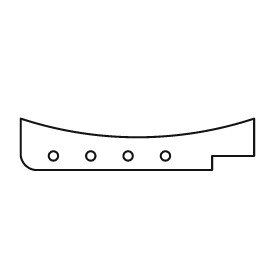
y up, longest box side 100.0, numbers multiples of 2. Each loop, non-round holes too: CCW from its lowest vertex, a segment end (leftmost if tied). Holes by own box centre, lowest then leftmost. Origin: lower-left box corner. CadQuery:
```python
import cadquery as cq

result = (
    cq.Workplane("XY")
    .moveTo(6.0, 0.0)
    .lineTo(82.0, 0.0)
    .lineTo(82.0, 6.0)
    .lineTo(100.0, 6.0)
    .lineTo(100.0, 22.0)
    .threePointArc((50.0, 14.0), (0.0, 22.0))
    .lineTo(0.0, 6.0)
    .threePointArc((2.0, 2.0), (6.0, 0.0))
    .close()
    .moveTo(14.0, 6.0)
    .circle(2.0)
    .moveTo(30.0, 6.0)
    .circle(2.0)
    .moveTo(46.0, 6.0)
    .circle(2.0)
    .moveTo(62.0, 6.0)
    .circle(2.0)
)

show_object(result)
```